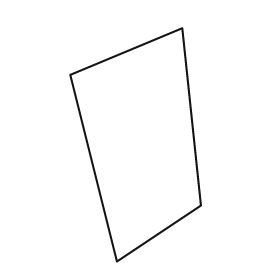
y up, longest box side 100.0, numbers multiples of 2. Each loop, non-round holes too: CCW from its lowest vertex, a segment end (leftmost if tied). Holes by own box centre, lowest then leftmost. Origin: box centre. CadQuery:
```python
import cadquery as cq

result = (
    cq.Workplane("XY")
    .moveTo(-8.0, -50.0)
    .lineTo(28.0, -26.0)
    .lineTo(20.0, 50.0)
    .lineTo(-28.0, 30.0)
    .close()
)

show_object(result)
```